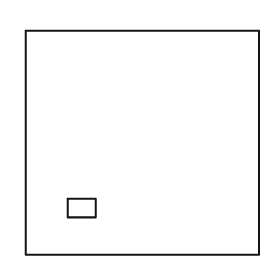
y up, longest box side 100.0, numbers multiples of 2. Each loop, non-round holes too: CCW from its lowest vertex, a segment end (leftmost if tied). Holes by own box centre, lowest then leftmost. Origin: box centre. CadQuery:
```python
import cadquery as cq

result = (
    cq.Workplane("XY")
    .moveTo(-50.0, -48.0)
    .lineTo(50.0, -48.0)
    .lineTo(50.0, 48.0)
    .lineTo(-50.0, 48.0)
    .close()
    .moveTo(-32.0, -32.0)
    .lineTo(-20.0, -32.0)
    .lineTo(-20.0, -24.0)
    .lineTo(-32.0, -24.0)
    .close()
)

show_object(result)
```